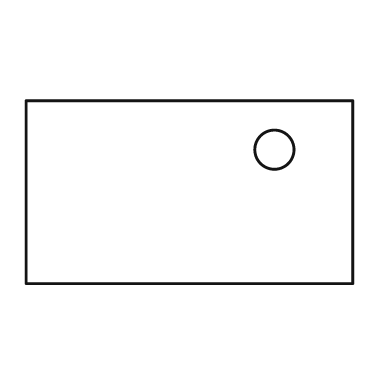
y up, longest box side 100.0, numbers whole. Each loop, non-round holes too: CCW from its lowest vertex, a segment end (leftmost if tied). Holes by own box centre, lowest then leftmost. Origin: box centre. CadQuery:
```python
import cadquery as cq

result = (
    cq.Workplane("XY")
    .moveTo(-50.0, -28.0)
    .lineTo(50.0, -28.0)
    .lineTo(50.0, 28.0)
    .lineTo(-50.0, 28.0)
    .close()
    .moveTo(26.0, 13.0)
    .circle(6.0)
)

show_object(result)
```